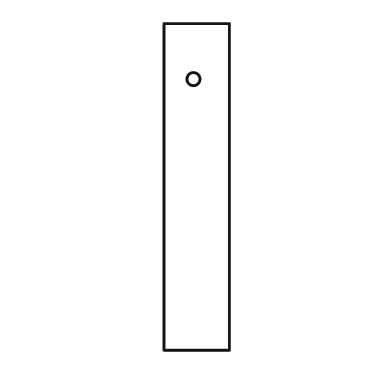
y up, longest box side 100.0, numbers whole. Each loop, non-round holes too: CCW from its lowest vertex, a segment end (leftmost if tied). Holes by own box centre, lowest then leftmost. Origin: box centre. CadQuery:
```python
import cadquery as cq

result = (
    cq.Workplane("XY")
    .moveTo(-10.0, -50.0)
    .lineTo(10.0, -50.0)
    .lineTo(10.0, 50.0)
    .lineTo(-10.0, 50.0)
    .close()
    .moveTo(-1.0, 33.0)
    .circle(2.0)
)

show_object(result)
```